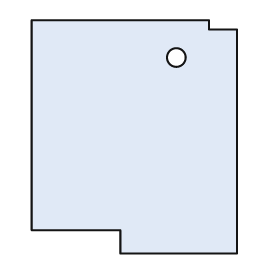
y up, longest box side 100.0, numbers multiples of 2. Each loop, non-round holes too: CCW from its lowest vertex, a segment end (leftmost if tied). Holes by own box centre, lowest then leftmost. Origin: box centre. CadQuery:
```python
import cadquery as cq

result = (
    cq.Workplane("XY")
    .moveTo(-6.0, -50.0)
    .lineTo(44.0, -50.0)
    .lineTo(44.0, 46.0)
    .lineTo(32.0, 46.0)
    .lineTo(32.0, 50.0)
    .lineTo(-44.0, 50.0)
    .lineTo(-44.0, -40.0)
    .lineTo(-6.0, -40.0)
    .close()
    .moveTo(18.0, 34.0)
    .circle(4.0)
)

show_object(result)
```